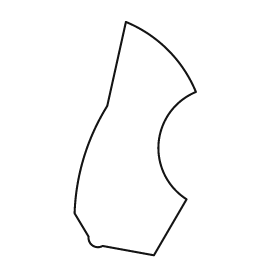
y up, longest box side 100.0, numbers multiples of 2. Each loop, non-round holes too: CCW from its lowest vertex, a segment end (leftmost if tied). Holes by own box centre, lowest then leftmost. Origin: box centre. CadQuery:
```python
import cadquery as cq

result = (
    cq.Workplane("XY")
    .moveTo(8.0, -50.0)
    .lineTo(22.0, -26.0)
    .threePointArc((10.0, -2.0), (26.0, 20.0))
    .threePointArc((14.0, 38.0), (-4.0, 50.0))
    .lineTo(-12.0, 14.0)
    .threePointArc((-22.0, -8.0), (-26.0, -32.0))
    .lineTo(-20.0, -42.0)
    .threePointArc((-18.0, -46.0), (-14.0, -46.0))
    .close()
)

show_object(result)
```